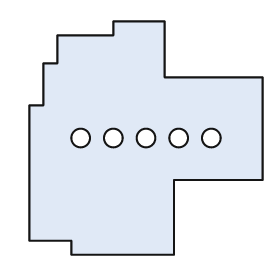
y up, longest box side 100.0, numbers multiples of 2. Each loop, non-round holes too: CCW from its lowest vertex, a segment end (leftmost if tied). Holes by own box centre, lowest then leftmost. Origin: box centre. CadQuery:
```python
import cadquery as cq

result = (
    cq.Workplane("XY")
    .moveTo(-32.0, -50.0)
    .lineTo(12.0, -50.0)
    .lineTo(12.0, -18.0)
    .lineTo(50.0, -18.0)
    .lineTo(50.0, 26.0)
    .lineTo(8.0, 26.0)
    .lineTo(8.0, 50.0)
    .lineTo(-14.0, 50.0)
    .lineTo(-14.0, 44.0)
    .lineTo(-38.0, 44.0)
    .lineTo(-38.0, 32.0)
    .lineTo(-44.0, 32.0)
    .lineTo(-44.0, 14.0)
    .lineTo(-50.0, 14.0)
    .lineTo(-50.0, -44.0)
    .lineTo(-32.0, -44.0)
    .close()
    .moveTo(-28.0, 0.0)
    .circle(4.0)
    .moveTo(-14.0, 0.0)
    .circle(4.0)
    .moveTo(0.0, 0.0)
    .circle(4.0)
    .moveTo(14.0, 0.0)
    .circle(4.0)
    .moveTo(28.0, 0.0)
    .circle(4.0)
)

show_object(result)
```